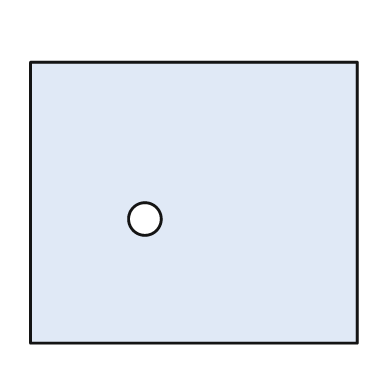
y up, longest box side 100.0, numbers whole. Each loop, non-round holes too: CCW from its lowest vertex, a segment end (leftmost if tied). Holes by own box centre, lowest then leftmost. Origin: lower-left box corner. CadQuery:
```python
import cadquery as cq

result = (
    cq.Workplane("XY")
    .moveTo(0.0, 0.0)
    .lineTo(100.0, 0.0)
    .lineTo(100.0, 86.0)
    .lineTo(0.0, 86.0)
    .close()
    .moveTo(35.0, 38.0)
    .circle(5.0)
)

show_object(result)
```